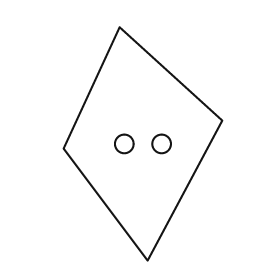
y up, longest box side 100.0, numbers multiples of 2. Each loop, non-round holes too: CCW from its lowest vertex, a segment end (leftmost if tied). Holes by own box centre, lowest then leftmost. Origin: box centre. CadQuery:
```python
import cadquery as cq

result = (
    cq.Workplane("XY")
    .moveTo(2.0, -50.0)
    .lineTo(34.0, 10.0)
    .lineTo(-10.0, 50.0)
    .lineTo(-34.0, -2.0)
    .close()
    .moveTo(-8.0, 0.0)
    .circle(4.0)
    .moveTo(8.0, 0.0)
    .circle(4.0)
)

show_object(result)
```